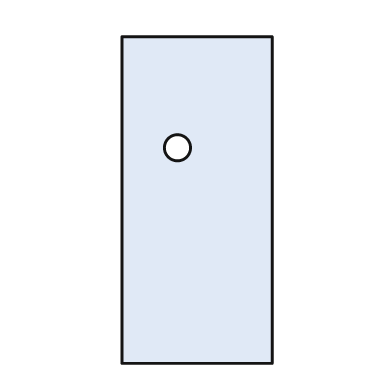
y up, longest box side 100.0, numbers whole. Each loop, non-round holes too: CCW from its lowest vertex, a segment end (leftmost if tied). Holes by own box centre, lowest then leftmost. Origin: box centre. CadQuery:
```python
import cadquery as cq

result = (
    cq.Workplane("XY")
    .moveTo(-23.0, -50.0)
    .lineTo(23.0, -50.0)
    .lineTo(23.0, 50.0)
    .lineTo(-23.0, 50.0)
    .close()
    .moveTo(-6.0, 16.0)
    .circle(4.0)
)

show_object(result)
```